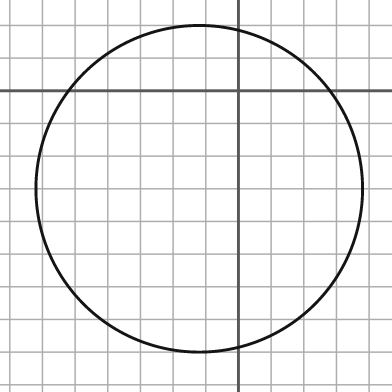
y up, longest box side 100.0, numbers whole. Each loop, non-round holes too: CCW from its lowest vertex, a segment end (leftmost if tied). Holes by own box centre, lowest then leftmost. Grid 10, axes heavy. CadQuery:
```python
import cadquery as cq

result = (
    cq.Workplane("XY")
    .moveTo(-12.0, -30.0)
    .circle(50.0)
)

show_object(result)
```